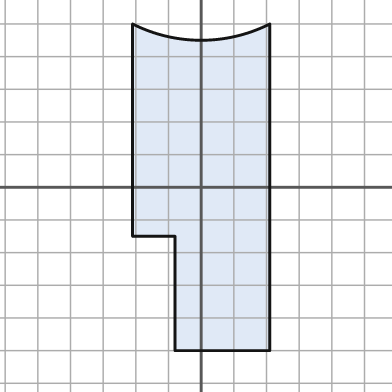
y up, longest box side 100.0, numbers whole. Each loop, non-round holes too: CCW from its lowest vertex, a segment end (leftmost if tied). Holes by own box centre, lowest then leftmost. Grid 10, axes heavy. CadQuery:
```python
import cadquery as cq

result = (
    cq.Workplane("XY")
    .moveTo(-8.0, -50.0)
    .lineTo(21.0, -50.0)
    .lineTo(21.0, 50.0)
    .threePointArc((0.0, 45.0), (-21.0, 50.0))
    .lineTo(-21.0, -15.0)
    .lineTo(-8.0, -15.0)
    .close()
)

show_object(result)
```